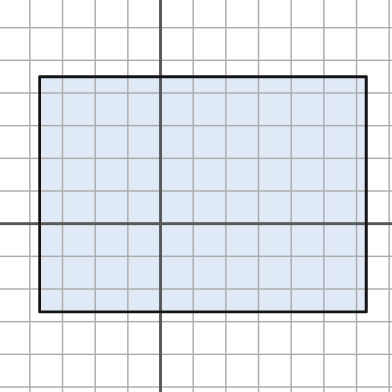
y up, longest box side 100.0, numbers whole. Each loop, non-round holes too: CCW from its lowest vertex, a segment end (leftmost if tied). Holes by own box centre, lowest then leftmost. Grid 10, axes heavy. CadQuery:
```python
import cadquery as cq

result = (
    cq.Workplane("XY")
    .moveTo(-37.0, -27.0)
    .lineTo(63.0, -27.0)
    .lineTo(63.0, 45.0)
    .lineTo(-37.0, 45.0)
    .close()
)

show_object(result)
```